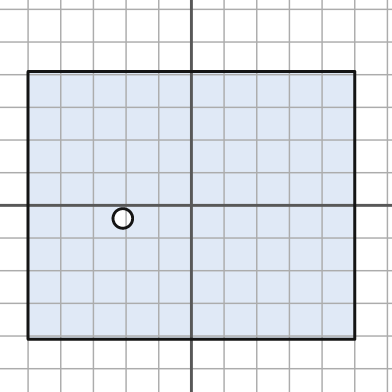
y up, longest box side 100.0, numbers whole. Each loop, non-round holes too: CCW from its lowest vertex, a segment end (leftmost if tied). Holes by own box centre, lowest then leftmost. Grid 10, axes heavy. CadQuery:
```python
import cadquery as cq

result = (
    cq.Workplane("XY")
    .moveTo(-50.0, -41.0)
    .lineTo(50.0, -41.0)
    .lineTo(50.0, 41.0)
    .lineTo(-50.0, 41.0)
    .close()
    .moveTo(-21.0, -4.0)
    .circle(3.0)
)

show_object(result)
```